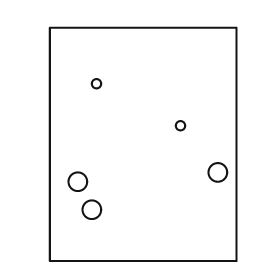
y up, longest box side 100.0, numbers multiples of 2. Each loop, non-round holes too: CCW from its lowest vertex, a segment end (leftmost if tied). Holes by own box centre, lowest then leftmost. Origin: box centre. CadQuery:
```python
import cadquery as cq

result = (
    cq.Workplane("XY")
    .moveTo(-40.0, -50.0)
    .lineTo(40.0, -50.0)
    .lineTo(40.0, 50.0)
    .lineTo(-40.0, 50.0)
    .close()
    .moveTo(-22.0, -28.0)
    .circle(4.0)
    .moveTo(-28.0, -16.0)
    .circle(4.0)
    .moveTo(32.0, -12.0)
    .circle(4.0)
    .moveTo(16.0, 8.0)
    .circle(2.0)
    .moveTo(-20.0, 26.0)
    .circle(2.0)
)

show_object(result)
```